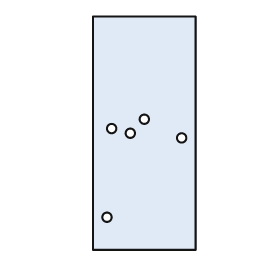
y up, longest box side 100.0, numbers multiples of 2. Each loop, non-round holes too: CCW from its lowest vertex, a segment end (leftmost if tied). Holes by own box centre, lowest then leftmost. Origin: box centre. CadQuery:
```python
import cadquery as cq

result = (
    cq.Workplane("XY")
    .moveTo(-22.0, -50.0)
    .lineTo(22.0, -50.0)
    .lineTo(22.0, 50.0)
    .lineTo(-22.0, 50.0)
    .close()
    .moveTo(-16.0, -36.0)
    .circle(2.0)
    .moveTo(16.0, -2.0)
    .circle(2.0)
    .moveTo(-6.0, 0.0)
    .circle(2.0)
    .moveTo(-14.0, 2.0)
    .circle(2.0)
    .moveTo(0.0, 6.0)
    .circle(2.0)
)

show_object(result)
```